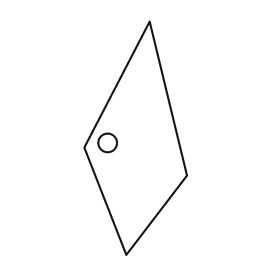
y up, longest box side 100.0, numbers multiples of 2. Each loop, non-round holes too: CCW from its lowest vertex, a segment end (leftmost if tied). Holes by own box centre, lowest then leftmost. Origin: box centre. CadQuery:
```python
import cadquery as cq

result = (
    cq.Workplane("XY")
    .moveTo(-4.0, -50.0)
    .lineTo(22.0, -16.0)
    .lineTo(6.0, 50.0)
    .lineTo(-22.0, -4.0)
    .close()
    .moveTo(-12.0, -2.0)
    .circle(4.0)
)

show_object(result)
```